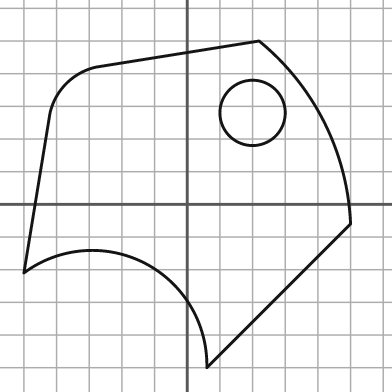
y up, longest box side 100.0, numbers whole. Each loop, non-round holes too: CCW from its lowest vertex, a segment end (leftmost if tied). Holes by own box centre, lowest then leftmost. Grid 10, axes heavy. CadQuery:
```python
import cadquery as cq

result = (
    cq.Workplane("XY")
    .moveTo(6.0, -50.0)
    .lineTo(50.0, -6.0)
    .threePointArc((42.0, 25.0), (22.0, 50.0))
    .lineTo(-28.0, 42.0)
    .threePointArc((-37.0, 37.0), (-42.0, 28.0))
    .lineTo(-50.0, -21.0)
    .threePointArc((-13.0, -18.0), (6.0, -50.0))
    .close()
    .moveTo(20.0, 28.0)
    .circle(10.0)
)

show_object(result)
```